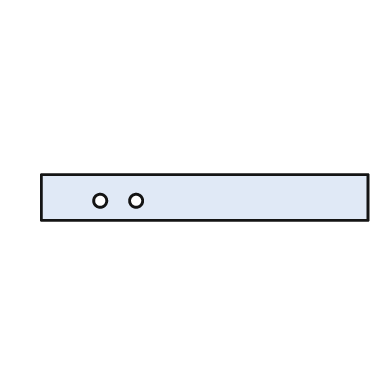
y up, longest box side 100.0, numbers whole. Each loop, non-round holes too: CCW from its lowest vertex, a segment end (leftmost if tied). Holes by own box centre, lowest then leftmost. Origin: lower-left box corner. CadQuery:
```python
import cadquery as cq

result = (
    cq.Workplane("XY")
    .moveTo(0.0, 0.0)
    .lineTo(100.0, 0.0)
    .lineTo(100.0, 14.0)
    .lineTo(0.0, 14.0)
    .close()
    .moveTo(18.0, 6.0)
    .circle(2.0)
    .moveTo(29.0, 6.0)
    .circle(2.0)
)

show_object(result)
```